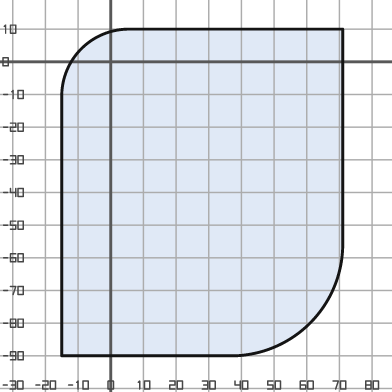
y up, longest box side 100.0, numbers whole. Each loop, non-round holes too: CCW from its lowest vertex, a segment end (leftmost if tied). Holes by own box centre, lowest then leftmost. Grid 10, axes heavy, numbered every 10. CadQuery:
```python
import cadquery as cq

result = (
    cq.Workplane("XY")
    .moveTo(-15.0, -90.0)
    .lineTo(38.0, -90.0)
    .threePointArc((61.0, -80.0), (71.0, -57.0))
    .lineTo(71.0, 10.0)
    .lineTo(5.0, 10.0)
    .threePointArc((-9.0, 4.0), (-15.0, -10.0))
    .close()
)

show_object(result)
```